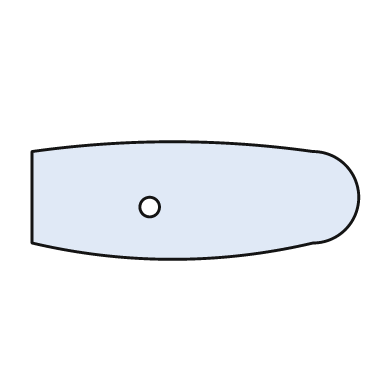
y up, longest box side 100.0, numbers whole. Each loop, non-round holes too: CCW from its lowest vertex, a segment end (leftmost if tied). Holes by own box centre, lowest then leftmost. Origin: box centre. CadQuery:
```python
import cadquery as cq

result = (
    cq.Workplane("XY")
    .moveTo(-50.0, -13.0)
    .threePointArc((-7.0, -18.0), (36.0, -13.0))
    .threePointArc((50.0, 1.0), (36.0, 15.0))
    .threePointArc((-7.0, 18.0), (-50.0, 15.0))
    .close()
    .moveTo(-14.0, -2.0)
    .circle(3.0)
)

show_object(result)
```